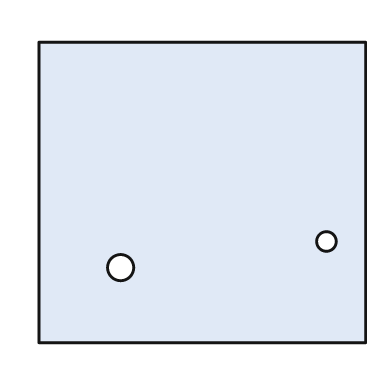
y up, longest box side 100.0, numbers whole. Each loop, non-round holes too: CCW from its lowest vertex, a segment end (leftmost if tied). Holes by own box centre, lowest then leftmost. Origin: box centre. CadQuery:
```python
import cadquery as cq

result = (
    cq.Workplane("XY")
    .moveTo(-50.0, -46.0)
    .lineTo(50.0, -46.0)
    .lineTo(50.0, 46.0)
    .lineTo(-50.0, 46.0)
    .close()
    .moveTo(-25.0, -23.0)
    .circle(4.0)
    .moveTo(38.0, -15.0)
    .circle(3.0)
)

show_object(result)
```